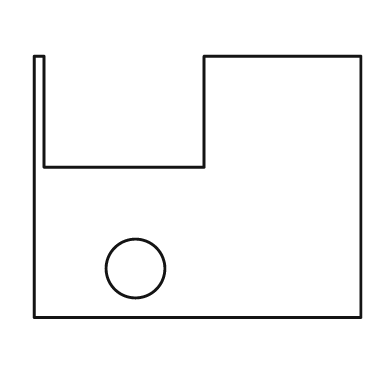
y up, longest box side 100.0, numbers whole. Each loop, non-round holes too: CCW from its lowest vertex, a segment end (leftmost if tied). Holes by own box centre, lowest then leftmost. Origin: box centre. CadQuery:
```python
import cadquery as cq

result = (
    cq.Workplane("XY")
    .moveTo(-50.0, -40.0)
    .lineTo(50.0, -40.0)
    .lineTo(50.0, 40.0)
    .lineTo(2.0, 40.0)
    .lineTo(2.0, 6.0)
    .lineTo(-47.0, 6.0)
    .lineTo(-47.0, 40.0)
    .lineTo(-50.0, 40.0)
    .close()
    .moveTo(-19.0, -25.0)
    .circle(9.0)
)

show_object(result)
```